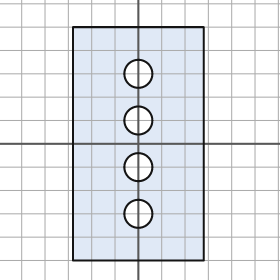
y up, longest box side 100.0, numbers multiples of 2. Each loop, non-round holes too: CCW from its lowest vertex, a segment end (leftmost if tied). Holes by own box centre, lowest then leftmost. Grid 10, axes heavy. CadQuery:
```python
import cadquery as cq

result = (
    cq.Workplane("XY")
    .moveTo(-28.0, -50.0)
    .lineTo(28.0, -50.0)
    .lineTo(28.0, 50.0)
    .lineTo(-28.0, 50.0)
    .close()
    .moveTo(0.0, -30.0)
    .circle(6.0)
    .moveTo(0.0, -10.0)
    .circle(6.0)
    .moveTo(0.0, 10.0)
    .circle(6.0)
    .moveTo(0.0, 30.0)
    .circle(6.0)
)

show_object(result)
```